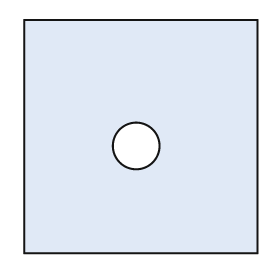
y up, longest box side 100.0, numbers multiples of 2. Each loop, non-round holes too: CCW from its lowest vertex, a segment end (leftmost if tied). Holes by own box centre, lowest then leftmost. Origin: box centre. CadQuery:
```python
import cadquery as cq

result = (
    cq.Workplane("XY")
    .moveTo(-50.0, -50.0)
    .lineTo(50.0, -50.0)
    .lineTo(50.0, 50.0)
    .lineTo(-50.0, 50.0)
    .close()
    .moveTo(-2.0, -4.0)
    .circle(10.0)
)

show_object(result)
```